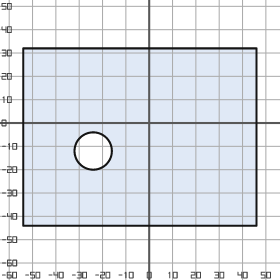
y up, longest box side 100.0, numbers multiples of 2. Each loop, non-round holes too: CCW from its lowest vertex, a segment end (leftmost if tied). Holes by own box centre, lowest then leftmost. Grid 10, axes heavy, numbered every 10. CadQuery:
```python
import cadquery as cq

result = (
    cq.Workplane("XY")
    .moveTo(-54.0, -44.0)
    .lineTo(46.0, -44.0)
    .lineTo(46.0, 32.0)
    .lineTo(-54.0, 32.0)
    .close()
    .moveTo(-24.0, -12.0)
    .circle(8.0)
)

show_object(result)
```